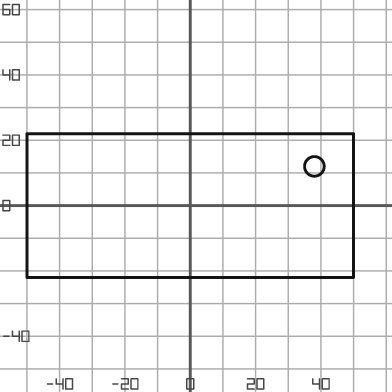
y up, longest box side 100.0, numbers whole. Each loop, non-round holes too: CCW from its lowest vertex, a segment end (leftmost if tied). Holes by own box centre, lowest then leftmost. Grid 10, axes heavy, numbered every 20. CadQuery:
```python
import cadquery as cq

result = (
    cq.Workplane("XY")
    .moveTo(-50.0, -22.0)
    .lineTo(50.0, -22.0)
    .lineTo(50.0, 22.0)
    .lineTo(-50.0, 22.0)
    .close()
    .moveTo(38.0, 12.0)
    .circle(3.0)
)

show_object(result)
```